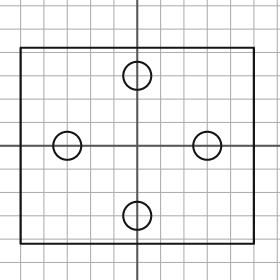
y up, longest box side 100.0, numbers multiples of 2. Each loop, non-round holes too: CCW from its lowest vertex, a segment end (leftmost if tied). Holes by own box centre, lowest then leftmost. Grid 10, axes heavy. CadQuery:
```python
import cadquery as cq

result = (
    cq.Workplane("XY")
    .moveTo(-50.0, -42.0)
    .lineTo(50.0, -42.0)
    .lineTo(50.0, 42.0)
    .lineTo(-50.0, 42.0)
    .close()
    .moveTo(0.0, -30.0)
    .circle(6.0)
    .moveTo(-30.0, 0.0)
    .circle(6.0)
    .moveTo(30.0, 0.0)
    .circle(6.0)
    .moveTo(0.0, 30.0)
    .circle(6.0)
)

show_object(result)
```